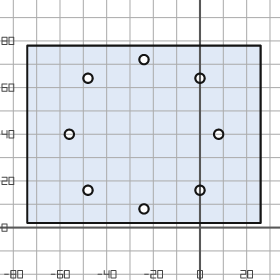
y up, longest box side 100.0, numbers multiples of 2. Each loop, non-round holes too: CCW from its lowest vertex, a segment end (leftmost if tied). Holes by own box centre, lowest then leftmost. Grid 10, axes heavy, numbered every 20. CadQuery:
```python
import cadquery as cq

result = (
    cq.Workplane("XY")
    .moveTo(-74.0, 2.0)
    .lineTo(26.0, 2.0)
    .lineTo(26.0, 78.0)
    .lineTo(-74.0, 78.0)
    .close()
    .moveTo(-24.0, 8.0)
    .circle(2.0)
    .moveTo(-48.0, 16.0)
    .circle(2.0)
    .moveTo(0.0, 16.0)
    .circle(2.0)
    .moveTo(-56.0, 40.0)
    .circle(2.0)
    .moveTo(8.0, 40.0)
    .circle(2.0)
    .moveTo(-48.0, 64.0)
    .circle(2.0)
    .moveTo(0.0, 64.0)
    .circle(2.0)
    .moveTo(-24.0, 72.0)
    .circle(2.0)
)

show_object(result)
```